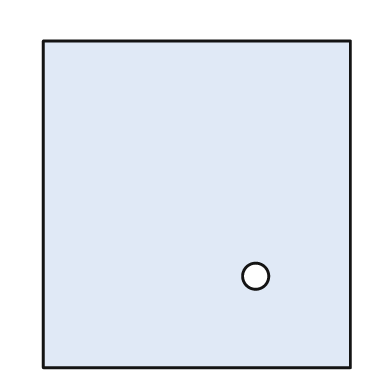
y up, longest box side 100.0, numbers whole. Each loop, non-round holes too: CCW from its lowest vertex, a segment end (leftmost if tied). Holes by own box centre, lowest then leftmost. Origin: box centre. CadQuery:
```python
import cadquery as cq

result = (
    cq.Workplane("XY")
    .moveTo(-47.0, -50.0)
    .lineTo(47.0, -50.0)
    .lineTo(47.0, 50.0)
    .lineTo(-47.0, 50.0)
    .close()
    .moveTo(18.0, -22.0)
    .circle(4.0)
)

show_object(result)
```